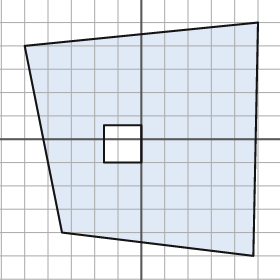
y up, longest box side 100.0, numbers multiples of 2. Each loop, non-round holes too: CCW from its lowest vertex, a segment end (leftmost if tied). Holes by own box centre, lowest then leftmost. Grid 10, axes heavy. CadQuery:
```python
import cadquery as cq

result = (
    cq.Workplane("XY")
    .moveTo(48.0, -50.0)
    .lineTo(50.0, 50.0)
    .lineTo(-50.0, 40.0)
    .lineTo(-34.0, -40.0)
    .close()
    .moveTo(-16.0, -10.0)
    .lineTo(0.0, -10.0)
    .lineTo(0.0, 6.0)
    .lineTo(-16.0, 6.0)
    .close()
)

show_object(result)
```